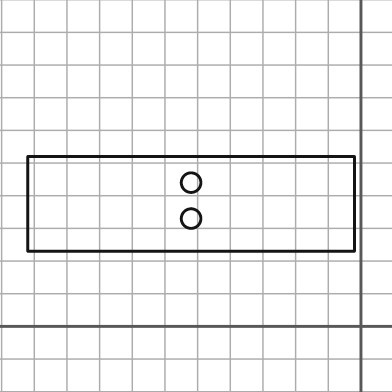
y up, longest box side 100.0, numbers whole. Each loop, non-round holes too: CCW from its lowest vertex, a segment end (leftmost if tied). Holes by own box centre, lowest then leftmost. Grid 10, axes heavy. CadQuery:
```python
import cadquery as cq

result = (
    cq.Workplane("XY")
    .moveTo(-102.0, 23.0)
    .lineTo(-2.0, 23.0)
    .lineTo(-2.0, 52.0)
    .lineTo(-102.0, 52.0)
    .close()
    .moveTo(-52.0, 33.0)
    .circle(3.0)
    .moveTo(-52.0, 44.0)
    .circle(3.0)
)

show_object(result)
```